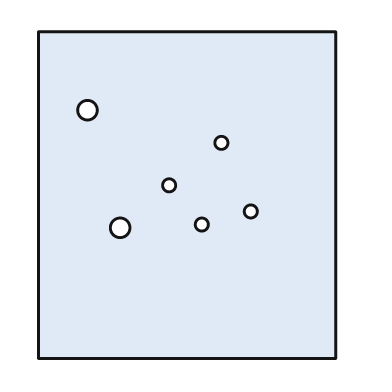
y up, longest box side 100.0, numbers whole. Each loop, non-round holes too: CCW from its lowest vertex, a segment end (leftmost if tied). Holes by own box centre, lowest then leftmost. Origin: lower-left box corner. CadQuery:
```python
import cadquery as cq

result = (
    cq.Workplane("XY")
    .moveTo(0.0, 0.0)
    .lineTo(91.0, 0.0)
    .lineTo(91.0, 100.0)
    .lineTo(0.0, 100.0)
    .close()
    .moveTo(25.0, 40.0)
    .circle(3.0)
    .moveTo(50.0, 41.0)
    .circle(2.0)
    .moveTo(65.0, 45.0)
    .circle(2.0)
    .moveTo(40.0, 53.0)
    .circle(2.0)
    .moveTo(56.0, 66.0)
    .circle(2.0)
    .moveTo(15.0, 76.0)
    .circle(3.0)
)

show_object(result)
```